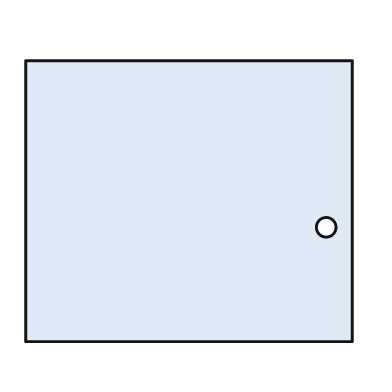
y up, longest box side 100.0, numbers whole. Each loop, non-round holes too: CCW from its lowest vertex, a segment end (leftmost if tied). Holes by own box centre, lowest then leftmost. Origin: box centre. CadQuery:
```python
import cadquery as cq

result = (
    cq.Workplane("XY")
    .moveTo(-50.0, -43.0)
    .lineTo(50.0, -43.0)
    .lineTo(50.0, 43.0)
    .lineTo(-50.0, 43.0)
    .close()
    .moveTo(42.0, -8.0)
    .circle(3.0)
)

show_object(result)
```